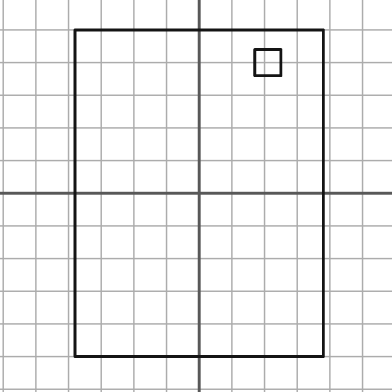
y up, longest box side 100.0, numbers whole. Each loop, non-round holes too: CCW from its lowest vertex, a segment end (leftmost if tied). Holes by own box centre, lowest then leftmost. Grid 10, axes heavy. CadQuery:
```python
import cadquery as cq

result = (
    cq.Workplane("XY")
    .moveTo(-38.0, -50.0)
    .lineTo(38.0, -50.0)
    .lineTo(38.0, 50.0)
    .lineTo(-38.0, 50.0)
    .close()
    .moveTo(17.0, 36.0)
    .lineTo(25.0, 36.0)
    .lineTo(25.0, 44.0)
    .lineTo(17.0, 44.0)
    .close()
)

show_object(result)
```